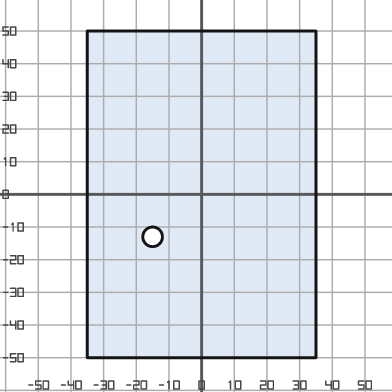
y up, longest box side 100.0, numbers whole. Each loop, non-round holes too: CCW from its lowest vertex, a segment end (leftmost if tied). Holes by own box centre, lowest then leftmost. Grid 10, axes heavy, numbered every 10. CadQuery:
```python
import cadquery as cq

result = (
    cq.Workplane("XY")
    .moveTo(-35.0, -50.0)
    .lineTo(35.0, -50.0)
    .lineTo(35.0, 50.0)
    .lineTo(-35.0, 50.0)
    .close()
    .moveTo(-15.0, -13.0)
    .circle(3.0)
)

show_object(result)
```